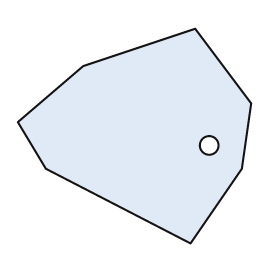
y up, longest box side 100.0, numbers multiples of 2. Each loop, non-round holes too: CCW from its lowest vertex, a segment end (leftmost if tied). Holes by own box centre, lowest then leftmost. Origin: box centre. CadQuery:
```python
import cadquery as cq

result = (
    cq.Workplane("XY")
    .moveTo(24.0, -46.0)
    .lineTo(46.0, -14.0)
    .lineTo(50.0, 14.0)
    .lineTo(26.0, 46.0)
    .lineTo(-22.0, 30.0)
    .lineTo(-50.0, 6.0)
    .lineTo(-38.0, -14.0)
    .close()
    .moveTo(32.0, -4.0)
    .circle(4.0)
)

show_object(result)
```